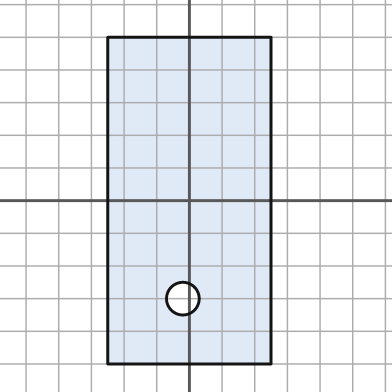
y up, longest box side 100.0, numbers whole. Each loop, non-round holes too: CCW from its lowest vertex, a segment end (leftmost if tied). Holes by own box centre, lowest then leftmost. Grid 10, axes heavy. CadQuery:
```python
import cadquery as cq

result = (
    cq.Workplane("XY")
    .moveTo(-25.0, -50.0)
    .lineTo(25.0, -50.0)
    .lineTo(25.0, 50.0)
    .lineTo(-25.0, 50.0)
    .close()
    .moveTo(-2.0, -30.0)
    .circle(5.0)
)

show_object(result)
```